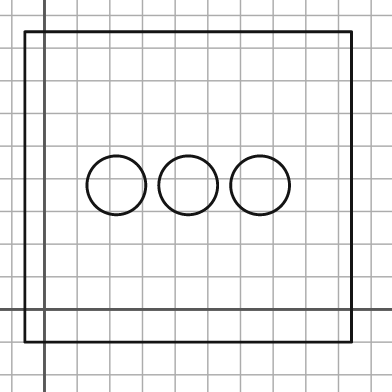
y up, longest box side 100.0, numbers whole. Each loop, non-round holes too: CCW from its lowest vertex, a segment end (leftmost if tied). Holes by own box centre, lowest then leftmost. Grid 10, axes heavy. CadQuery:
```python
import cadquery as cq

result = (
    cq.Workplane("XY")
    .moveTo(-6.0, -10.0)
    .lineTo(94.0, -10.0)
    .lineTo(94.0, 85.0)
    .lineTo(-6.0, 85.0)
    .close()
    .moveTo(22.0, 38.0)
    .circle(9.0)
    .moveTo(44.0, 38.0)
    .circle(9.0)
    .moveTo(66.0, 38.0)
    .circle(9.0)
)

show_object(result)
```